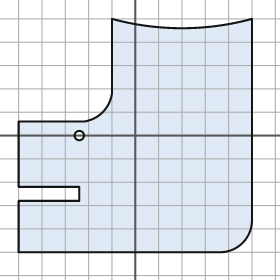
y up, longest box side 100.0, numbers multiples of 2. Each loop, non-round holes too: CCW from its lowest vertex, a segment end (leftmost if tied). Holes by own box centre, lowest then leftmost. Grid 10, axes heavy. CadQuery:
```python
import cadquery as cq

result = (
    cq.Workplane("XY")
    .moveTo(-50.0, -50.0)
    .lineTo(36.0, -50.0)
    .threePointArc((46.0, -46.0), (50.0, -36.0))
    .lineTo(50.0, 50.0)
    .threePointArc((20.0, 46.0), (-10.0, 50.0))
    .lineTo(-10.0, 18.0)
    .threePointArc((-14.0, 10.0), (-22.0, 6.0))
    .lineTo(-50.0, 6.0)
    .lineTo(-50.0, -22.0)
    .lineTo(-24.0, -22.0)
    .lineTo(-24.0, -28.0)
    .lineTo(-50.0, -28.0)
    .close()
    .moveTo(-24.0, 0.0)
    .circle(2.0)
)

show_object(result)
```